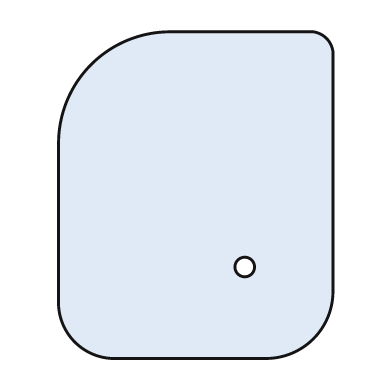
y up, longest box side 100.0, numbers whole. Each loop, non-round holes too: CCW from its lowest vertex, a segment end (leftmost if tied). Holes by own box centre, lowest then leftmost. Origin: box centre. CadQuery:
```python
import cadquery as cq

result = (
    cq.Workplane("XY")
    .moveTo(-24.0, -50.0)
    .lineTo(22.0, -50.0)
    .threePointArc((36.0, -44.0), (42.0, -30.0))
    .lineTo(42.0, 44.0)
    .threePointArc((40.0, 48.0), (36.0, 50.0))
    .lineTo(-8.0, 50.0)
    .threePointArc((-32.0, 40.0), (-42.0, 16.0))
    .lineTo(-42.0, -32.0)
    .threePointArc((-37.0, -45.0), (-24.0, -50.0))
    .close()
    .moveTo(15.0, -22.0)
    .circle(3.0)
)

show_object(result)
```